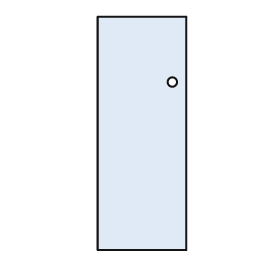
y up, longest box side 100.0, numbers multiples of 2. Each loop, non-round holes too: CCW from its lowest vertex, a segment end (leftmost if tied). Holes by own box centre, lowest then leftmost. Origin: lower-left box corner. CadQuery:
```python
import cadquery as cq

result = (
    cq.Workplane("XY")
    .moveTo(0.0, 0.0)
    .lineTo(38.0, 0.0)
    .lineTo(38.0, 100.0)
    .lineTo(0.0, 100.0)
    .close()
    .moveTo(32.0, 72.0)
    .circle(2.0)
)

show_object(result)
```